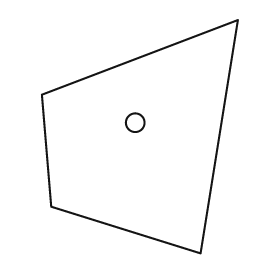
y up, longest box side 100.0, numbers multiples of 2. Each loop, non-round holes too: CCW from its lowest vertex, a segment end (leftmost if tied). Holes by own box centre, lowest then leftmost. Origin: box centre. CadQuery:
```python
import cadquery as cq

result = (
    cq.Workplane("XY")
    .moveTo(26.0, -50.0)
    .lineTo(42.0, 50.0)
    .lineTo(-42.0, 18.0)
    .lineTo(-38.0, -30.0)
    .close()
    .moveTo(-2.0, 6.0)
    .circle(4.0)
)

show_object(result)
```